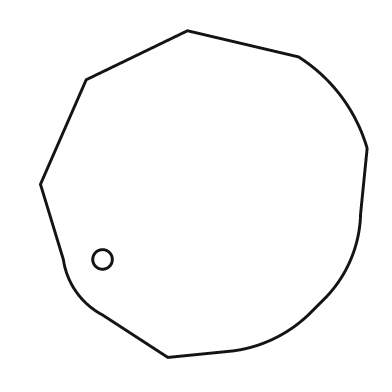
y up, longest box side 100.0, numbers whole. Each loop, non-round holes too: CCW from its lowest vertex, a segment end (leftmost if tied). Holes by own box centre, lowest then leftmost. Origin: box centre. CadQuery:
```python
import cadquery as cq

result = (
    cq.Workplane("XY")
    .moveTo(-11.0, -50.0)
    .lineTo(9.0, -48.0)
    .threePointArc((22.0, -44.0), (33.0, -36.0))
    .lineTo(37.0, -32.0)
    .threePointArc((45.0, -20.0), (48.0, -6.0))
    .lineTo(50.0, 14.0)
    .threePointArc((42.0, 30.0), (29.0, 42.0))
    .lineTo(-5.0, 50.0)
    .lineTo(-36.0, 35.0)
    .lineTo(-50.0, 3.0)
    .lineTo(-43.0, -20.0)
    .threePointArc((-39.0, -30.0), (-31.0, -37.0))
    .close()
    .moveTo(-31.0, -20.0)
    .circle(3.0)
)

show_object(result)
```